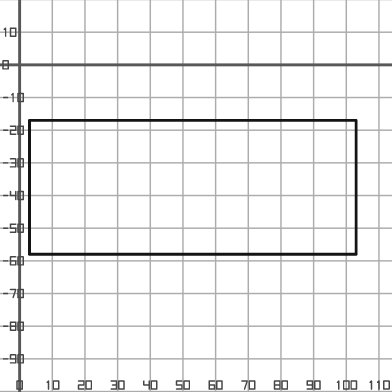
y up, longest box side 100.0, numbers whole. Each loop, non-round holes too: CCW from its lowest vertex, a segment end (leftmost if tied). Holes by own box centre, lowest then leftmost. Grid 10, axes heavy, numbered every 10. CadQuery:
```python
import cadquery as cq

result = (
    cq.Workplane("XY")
    .moveTo(3.0, -58.0)
    .lineTo(103.0, -58.0)
    .lineTo(103.0, -17.0)
    .lineTo(3.0, -17.0)
    .close()
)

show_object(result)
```